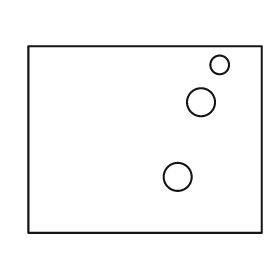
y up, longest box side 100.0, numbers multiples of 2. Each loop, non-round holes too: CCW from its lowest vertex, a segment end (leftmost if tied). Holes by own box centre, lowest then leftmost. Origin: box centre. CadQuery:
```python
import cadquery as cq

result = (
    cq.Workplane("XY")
    .moveTo(-50.0, -40.0)
    .lineTo(50.0, -40.0)
    .lineTo(50.0, 40.0)
    .lineTo(-50.0, 40.0)
    .close()
    .moveTo(14.0, -16.0)
    .circle(6.0)
    .moveTo(24.0, 16.0)
    .circle(6.0)
    .moveTo(32.0, 32.0)
    .circle(4.0)
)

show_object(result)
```